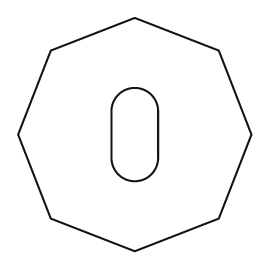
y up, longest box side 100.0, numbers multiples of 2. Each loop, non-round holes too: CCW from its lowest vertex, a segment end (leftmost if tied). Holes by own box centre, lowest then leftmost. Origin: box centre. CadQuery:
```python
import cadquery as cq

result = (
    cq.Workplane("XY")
    .moveTo(0.0, -50.0)
    .lineTo(36.0, -36.0)
    .lineTo(50.0, 0.0)
    .lineTo(36.0, 36.0)
    .lineTo(0.0, 50.0)
    .lineTo(-36.0, 36.0)
    .lineTo(-50.0, 0.0)
    .lineTo(-36.0, -36.0)
    .close()
    .moveTo(-10.0, -10.0)
    .threePointArc((0.0, -20.0), (10.0, -10.0))
    .lineTo(10.0, 10.0)
    .threePointArc((0.0, 20.0), (-10.0, 10.0))
    .close()
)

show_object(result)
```